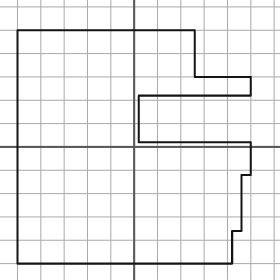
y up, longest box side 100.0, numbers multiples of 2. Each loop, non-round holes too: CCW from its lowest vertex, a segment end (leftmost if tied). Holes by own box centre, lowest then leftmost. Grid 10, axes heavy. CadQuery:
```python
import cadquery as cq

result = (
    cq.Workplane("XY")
    .moveTo(-50.0, -50.0)
    .lineTo(42.0, -50.0)
    .lineTo(42.0, -36.0)
    .lineTo(46.0, -36.0)
    .lineTo(46.0, -12.0)
    .lineTo(50.0, -12.0)
    .lineTo(50.0, 2.0)
    .lineTo(2.0, 2.0)
    .lineTo(2.0, 22.0)
    .lineTo(50.0, 22.0)
    .lineTo(50.0, 30.0)
    .lineTo(26.0, 30.0)
    .lineTo(26.0, 50.0)
    .lineTo(-50.0, 50.0)
    .close()
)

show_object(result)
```